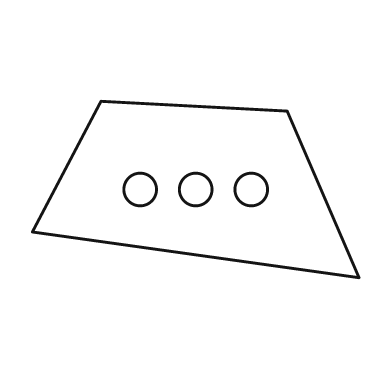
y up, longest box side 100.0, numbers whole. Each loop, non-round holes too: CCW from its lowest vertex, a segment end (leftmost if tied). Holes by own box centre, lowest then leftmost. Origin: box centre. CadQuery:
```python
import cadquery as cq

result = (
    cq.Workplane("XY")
    .moveTo(50.0, -27.0)
    .lineTo(28.0, 24.0)
    .lineTo(-29.0, 27.0)
    .lineTo(-50.0, -13.0)
    .close()
    .moveTo(-17.0, 0.0)
    .circle(5.0)
    .moveTo(0.0, 0.0)
    .circle(5.0)
    .moveTo(17.0, 0.0)
    .circle(5.0)
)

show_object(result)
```